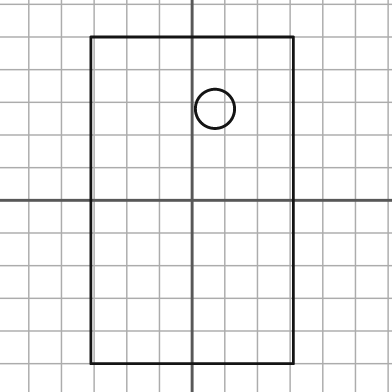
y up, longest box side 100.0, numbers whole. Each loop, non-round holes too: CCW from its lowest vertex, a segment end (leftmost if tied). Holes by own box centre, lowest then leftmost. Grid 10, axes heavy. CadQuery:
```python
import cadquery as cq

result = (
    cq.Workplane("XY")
    .moveTo(-31.0, -50.0)
    .lineTo(31.0, -50.0)
    .lineTo(31.0, 50.0)
    .lineTo(-31.0, 50.0)
    .close()
    .moveTo(7.0, 28.0)
    .circle(6.0)
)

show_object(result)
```